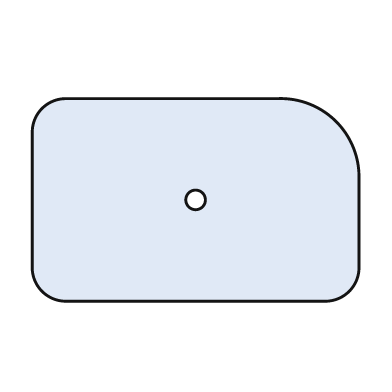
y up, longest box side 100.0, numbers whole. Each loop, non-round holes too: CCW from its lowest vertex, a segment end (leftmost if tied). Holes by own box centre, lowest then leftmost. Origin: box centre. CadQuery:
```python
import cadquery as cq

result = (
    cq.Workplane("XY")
    .moveTo(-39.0, -31.0)
    .lineTo(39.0, -31.0)
    .threePointArc((47.0, -28.0), (50.0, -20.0))
    .lineTo(50.0, 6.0)
    .threePointArc((43.0, 24.0), (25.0, 31.0))
    .lineTo(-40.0, 31.0)
    .threePointArc((-47.0, 28.0), (-50.0, 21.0))
    .lineTo(-50.0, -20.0)
    .threePointArc((-47.0, -28.0), (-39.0, -31.0))
    .close()
    .moveTo(0.0, 0.0)
    .circle(3.0)
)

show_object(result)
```